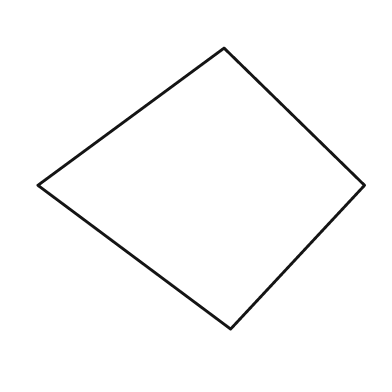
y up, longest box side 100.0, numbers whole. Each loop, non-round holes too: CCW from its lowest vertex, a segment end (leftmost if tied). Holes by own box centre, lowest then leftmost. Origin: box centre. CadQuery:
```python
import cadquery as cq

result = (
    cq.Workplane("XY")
    .moveTo(9.0, -43.0)
    .lineTo(50.0, 1.0)
    .lineTo(7.0, 43.0)
    .lineTo(-50.0, 1.0)
    .close()
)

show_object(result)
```